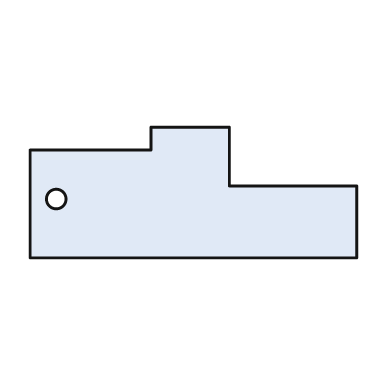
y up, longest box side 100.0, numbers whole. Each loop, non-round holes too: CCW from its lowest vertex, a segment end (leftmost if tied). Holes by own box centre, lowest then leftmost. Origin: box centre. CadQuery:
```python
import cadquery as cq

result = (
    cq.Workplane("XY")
    .moveTo(-50.0, -20.0)
    .lineTo(50.0, -20.0)
    .lineTo(50.0, 2.0)
    .lineTo(11.0, 2.0)
    .lineTo(11.0, 20.0)
    .lineTo(-13.0, 20.0)
    .lineTo(-13.0, 13.0)
    .lineTo(-50.0, 13.0)
    .close()
    .moveTo(-42.0, -2.0)
    .circle(3.0)
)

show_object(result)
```